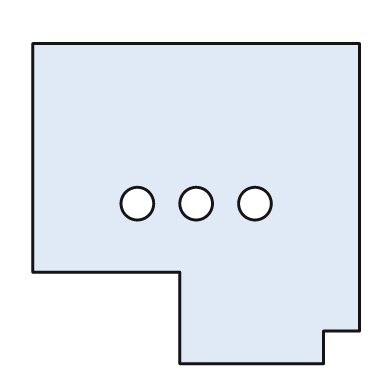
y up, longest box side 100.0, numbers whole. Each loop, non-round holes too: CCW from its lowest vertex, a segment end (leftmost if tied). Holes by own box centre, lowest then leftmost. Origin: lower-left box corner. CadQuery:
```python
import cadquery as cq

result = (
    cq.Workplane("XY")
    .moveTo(45.0, 0.0)
    .lineTo(89.0, 0.0)
    .lineTo(89.0, 10.0)
    .lineTo(100.0, 10.0)
    .lineTo(100.0, 98.0)
    .lineTo(0.0, 98.0)
    .lineTo(0.0, 28.0)
    .lineTo(45.0, 28.0)
    .close()
    .moveTo(32.0, 49.0)
    .circle(5.0)
    .moveTo(50.0, 49.0)
    .circle(5.0)
    .moveTo(68.0, 49.0)
    .circle(5.0)
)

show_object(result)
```